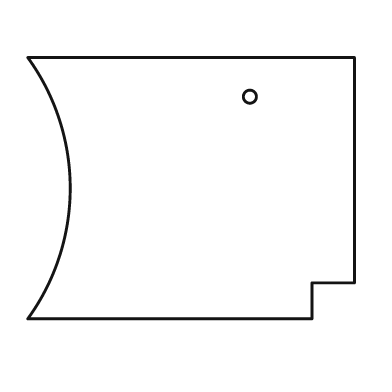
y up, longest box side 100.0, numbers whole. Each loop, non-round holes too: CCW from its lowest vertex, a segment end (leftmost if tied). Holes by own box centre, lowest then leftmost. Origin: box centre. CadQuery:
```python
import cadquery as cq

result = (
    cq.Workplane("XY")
    .moveTo(-50.0, -40.0)
    .lineTo(37.0, -40.0)
    .lineTo(37.0, -29.0)
    .lineTo(50.0, -29.0)
    .lineTo(50.0, 40.0)
    .lineTo(-50.0, 40.0)
    .threePointArc((-37.0, 0.0), (-50.0, -40.0))
    .close()
    .moveTo(18.0, 28.0)
    .circle(2.0)
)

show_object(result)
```